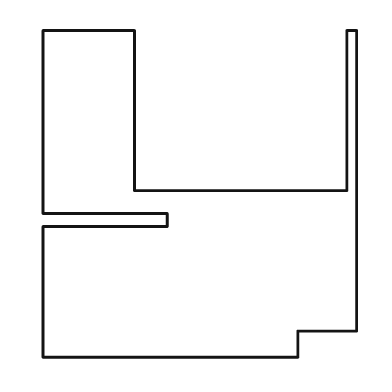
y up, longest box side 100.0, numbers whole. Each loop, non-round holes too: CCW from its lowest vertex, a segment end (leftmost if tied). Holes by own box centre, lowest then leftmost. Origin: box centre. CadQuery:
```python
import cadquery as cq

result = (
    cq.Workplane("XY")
    .moveTo(-48.0, -50.0)
    .lineTo(30.0, -50.0)
    .lineTo(30.0, -42.0)
    .lineTo(48.0, -42.0)
    .lineTo(48.0, 50.0)
    .lineTo(45.0, 50.0)
    .lineTo(45.0, 1.0)
    .lineTo(-20.0, 1.0)
    .lineTo(-20.0, 50.0)
    .lineTo(-48.0, 50.0)
    .lineTo(-48.0, -6.0)
    .lineTo(-10.0, -6.0)
    .lineTo(-10.0, -10.0)
    .lineTo(-48.0, -10.0)
    .close()
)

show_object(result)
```